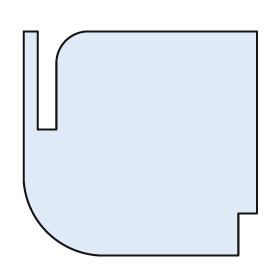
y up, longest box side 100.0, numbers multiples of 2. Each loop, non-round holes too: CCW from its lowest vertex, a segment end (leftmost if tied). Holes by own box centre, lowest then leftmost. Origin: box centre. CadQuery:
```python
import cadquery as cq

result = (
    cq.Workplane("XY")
    .moveTo(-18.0, -48.0)
    .lineTo(42.0, -48.0)
    .lineTo(42.0, -30.0)
    .lineTo(50.0, -30.0)
    .lineTo(50.0, 48.0)
    .lineTo(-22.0, 48.0)
    .threePointArc((-32.0, 44.0), (-36.0, 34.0))
    .lineTo(-36.0, 6.0)
    .lineTo(-44.0, 6.0)
    .lineTo(-44.0, 48.0)
    .lineTo(-50.0, 48.0)
    .lineTo(-50.0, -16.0)
    .threePointArc((-40.0, -38.0), (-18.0, -48.0))
    .close()
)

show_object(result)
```